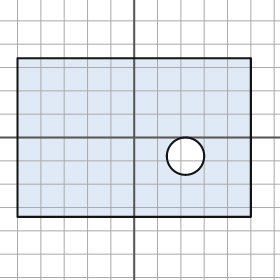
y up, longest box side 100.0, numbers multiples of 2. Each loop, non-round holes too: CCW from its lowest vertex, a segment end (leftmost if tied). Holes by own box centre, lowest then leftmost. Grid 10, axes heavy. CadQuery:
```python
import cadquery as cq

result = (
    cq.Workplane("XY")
    .moveTo(-50.0, -34.0)
    .lineTo(50.0, -34.0)
    .lineTo(50.0, 34.0)
    .lineTo(-50.0, 34.0)
    .close()
    .moveTo(22.0, -8.0)
    .circle(8.0)
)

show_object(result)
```